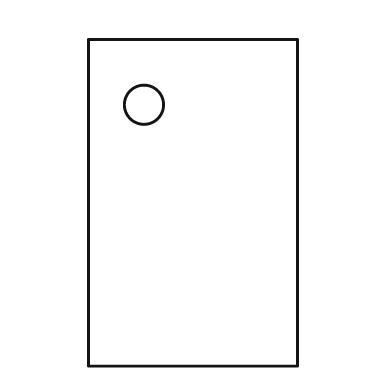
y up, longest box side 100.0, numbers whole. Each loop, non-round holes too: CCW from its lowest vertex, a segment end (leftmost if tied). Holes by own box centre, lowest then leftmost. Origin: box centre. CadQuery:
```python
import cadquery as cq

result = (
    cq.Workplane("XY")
    .moveTo(-32.0, -50.0)
    .lineTo(32.0, -50.0)
    .lineTo(32.0, 50.0)
    .lineTo(-32.0, 50.0)
    .close()
    .moveTo(-15.0, 30.0)
    .circle(6.0)
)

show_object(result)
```